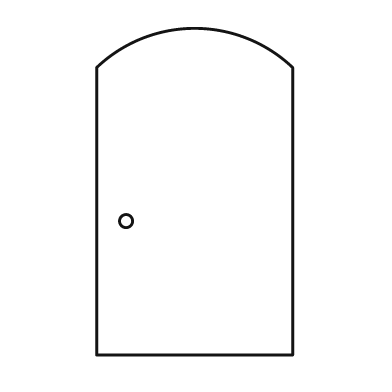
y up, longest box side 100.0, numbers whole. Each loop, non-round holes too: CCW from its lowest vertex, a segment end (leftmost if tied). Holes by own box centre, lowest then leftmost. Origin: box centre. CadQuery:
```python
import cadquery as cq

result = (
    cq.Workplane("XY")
    .moveTo(-30.0, -50.0)
    .lineTo(30.0, -50.0)
    .lineTo(30.0, 38.0)
    .threePointArc((0.0, 50.0), (-30.0, 38.0))
    .close()
    .moveTo(-21.0, -9.0)
    .circle(2.0)
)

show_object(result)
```